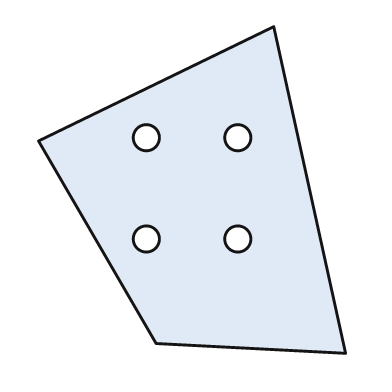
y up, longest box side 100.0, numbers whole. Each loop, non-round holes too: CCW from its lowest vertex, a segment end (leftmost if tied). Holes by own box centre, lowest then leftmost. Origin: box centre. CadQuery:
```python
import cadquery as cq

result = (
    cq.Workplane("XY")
    .moveTo(47.0, -50.0)
    .lineTo(25.0, 50.0)
    .lineTo(-47.0, 15.0)
    .lineTo(-11.0, -47.0)
    .close()
    .moveTo(-14.0, -15.0)
    .circle(4.0)
    .moveTo(14.0, -15.0)
    .circle(4.0)
    .moveTo(-14.0, 16.0)
    .circle(4.0)
    .moveTo(14.0, 16.0)
    .circle(4.0)
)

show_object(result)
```